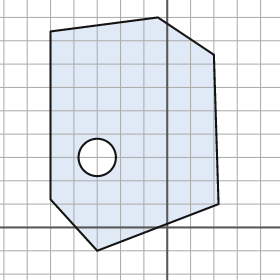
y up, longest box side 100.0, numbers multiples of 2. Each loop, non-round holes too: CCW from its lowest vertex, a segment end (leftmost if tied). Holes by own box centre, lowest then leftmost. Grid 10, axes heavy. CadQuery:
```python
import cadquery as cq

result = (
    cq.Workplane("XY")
    .moveTo(-30.0, -10.0)
    .lineTo(22.0, 10.0)
    .lineTo(20.0, 74.0)
    .lineTo(-4.0, 90.0)
    .lineTo(-50.0, 84.0)
    .lineTo(-50.0, 12.0)
    .close()
    .moveTo(-30.0, 30.0)
    .circle(8.0)
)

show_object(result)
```